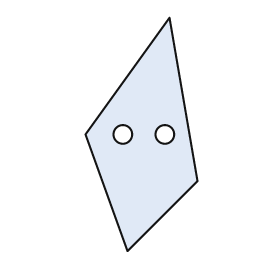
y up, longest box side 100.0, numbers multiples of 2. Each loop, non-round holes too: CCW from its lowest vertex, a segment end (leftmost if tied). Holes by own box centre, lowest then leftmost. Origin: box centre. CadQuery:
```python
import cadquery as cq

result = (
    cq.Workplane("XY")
    .moveTo(-6.0, -50.0)
    .lineTo(24.0, -20.0)
    .lineTo(12.0, 50.0)
    .lineTo(-24.0, 0.0)
    .close()
    .moveTo(-8.0, 0.0)
    .circle(4.0)
    .moveTo(10.0, 0.0)
    .circle(4.0)
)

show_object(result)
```